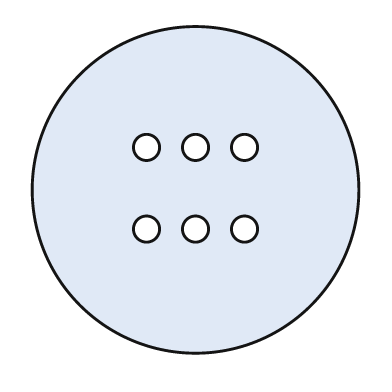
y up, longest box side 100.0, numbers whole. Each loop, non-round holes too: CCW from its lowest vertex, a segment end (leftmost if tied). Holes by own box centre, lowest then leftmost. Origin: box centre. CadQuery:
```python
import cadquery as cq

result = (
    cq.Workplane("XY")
    .moveTo(0.0, 0.0)
    .circle(50.0)
    .moveTo(-15.0, -12.0)
    .circle(4.0)
    .moveTo(0.0, -12.0)
    .circle(4.0)
    .moveTo(15.0, -12.0)
    .circle(4.0)
    .moveTo(-15.0, 13.0)
    .circle(4.0)
    .moveTo(0.0, 13.0)
    .circle(4.0)
    .moveTo(15.0, 13.0)
    .circle(4.0)
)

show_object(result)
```